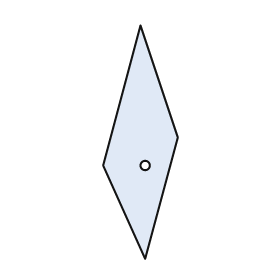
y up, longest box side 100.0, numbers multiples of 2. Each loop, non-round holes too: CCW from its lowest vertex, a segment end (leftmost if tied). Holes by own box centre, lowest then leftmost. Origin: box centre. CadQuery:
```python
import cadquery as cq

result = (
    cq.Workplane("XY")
    .moveTo(2.0, -50.0)
    .lineTo(16.0, 2.0)
    .lineTo(0.0, 50.0)
    .lineTo(-16.0, -10.0)
    .close()
    .moveTo(2.0, -10.0)
    .circle(2.0)
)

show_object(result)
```